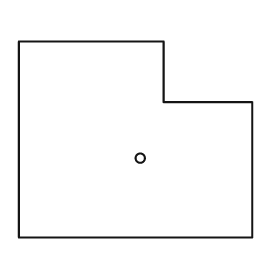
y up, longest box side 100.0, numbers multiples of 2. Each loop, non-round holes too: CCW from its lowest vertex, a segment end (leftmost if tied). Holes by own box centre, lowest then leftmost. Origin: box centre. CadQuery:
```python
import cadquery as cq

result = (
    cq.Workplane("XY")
    .moveTo(-50.0, -42.0)
    .lineTo(50.0, -42.0)
    .lineTo(50.0, 16.0)
    .lineTo(12.0, 16.0)
    .lineTo(12.0, 42.0)
    .lineTo(-50.0, 42.0)
    .close()
    .moveTo(2.0, -8.0)
    .circle(2.0)
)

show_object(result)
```